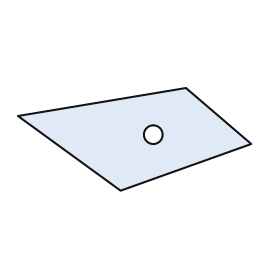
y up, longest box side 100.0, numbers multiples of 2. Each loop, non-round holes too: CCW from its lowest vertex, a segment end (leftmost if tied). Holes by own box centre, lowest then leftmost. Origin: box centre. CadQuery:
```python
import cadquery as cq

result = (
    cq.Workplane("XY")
    .moveTo(-6.0, -22.0)
    .lineTo(50.0, -2.0)
    .lineTo(22.0, 22.0)
    .lineTo(-50.0, 10.0)
    .close()
    .moveTo(8.0, 2.0)
    .circle(4.0)
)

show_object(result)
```